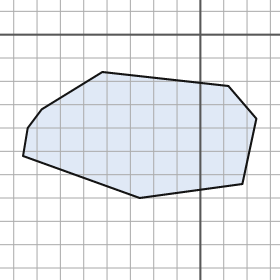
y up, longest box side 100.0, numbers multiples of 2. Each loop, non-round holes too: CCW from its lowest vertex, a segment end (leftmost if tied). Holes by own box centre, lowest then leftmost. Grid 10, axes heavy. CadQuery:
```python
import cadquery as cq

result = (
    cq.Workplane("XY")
    .moveTo(-26.0, -70.0)
    .lineTo(18.0, -64.0)
    .lineTo(24.0, -36.0)
    .lineTo(12.0, -22.0)
    .lineTo(-42.0, -16.0)
    .lineTo(-68.0, -32.0)
    .lineTo(-74.0, -40.0)
    .lineTo(-76.0, -52.0)
    .close()
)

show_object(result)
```